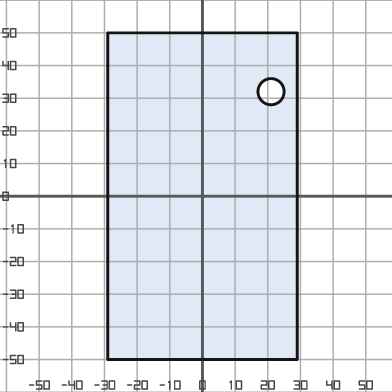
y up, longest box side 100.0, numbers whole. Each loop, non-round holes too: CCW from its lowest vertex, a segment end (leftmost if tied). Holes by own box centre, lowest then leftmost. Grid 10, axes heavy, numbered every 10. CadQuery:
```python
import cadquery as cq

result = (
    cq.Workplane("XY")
    .moveTo(-29.0, -50.0)
    .lineTo(29.0, -50.0)
    .lineTo(29.0, 50.0)
    .lineTo(-29.0, 50.0)
    .close()
    .moveTo(21.0, 32.0)
    .circle(4.0)
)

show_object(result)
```